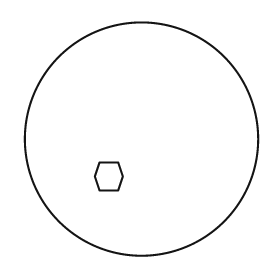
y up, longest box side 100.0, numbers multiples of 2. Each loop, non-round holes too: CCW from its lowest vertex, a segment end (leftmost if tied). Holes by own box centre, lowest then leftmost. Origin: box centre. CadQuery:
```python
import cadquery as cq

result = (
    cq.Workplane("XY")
    .moveTo(0.0, 0.0)
    .circle(50.0)
    .moveTo(-18.0, -22.0)
    .lineTo(-10.0, -22.0)
    .lineTo(-8.0, -16.0)
    .lineTo(-10.0, -10.0)
    .lineTo(-18.0, -10.0)
    .lineTo(-20.0, -16.0)
    .close()
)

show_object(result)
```